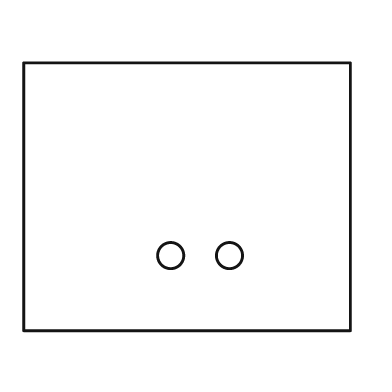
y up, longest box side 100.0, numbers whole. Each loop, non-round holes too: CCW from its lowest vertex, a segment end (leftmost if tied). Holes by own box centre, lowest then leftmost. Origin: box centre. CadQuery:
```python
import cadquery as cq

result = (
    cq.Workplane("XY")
    .moveTo(-50.0, -41.0)
    .lineTo(50.0, -41.0)
    .lineTo(50.0, 41.0)
    .lineTo(-50.0, 41.0)
    .close()
    .moveTo(-5.0, -18.0)
    .circle(4.0)
    .moveTo(13.0, -18.0)
    .circle(4.0)
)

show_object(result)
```